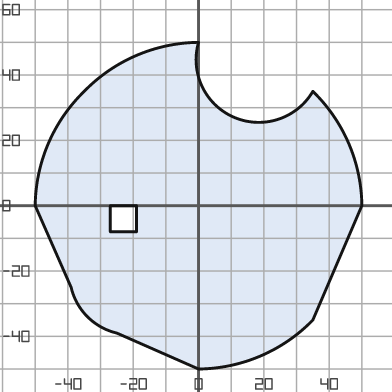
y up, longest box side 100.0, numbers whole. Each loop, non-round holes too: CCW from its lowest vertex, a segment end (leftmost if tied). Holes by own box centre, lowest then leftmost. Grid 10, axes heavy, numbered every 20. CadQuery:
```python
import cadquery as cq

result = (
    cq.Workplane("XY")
    .moveTo(0.0, -50.0)
    .threePointArc((19.0, -46.0), (35.0, -35.0))
    .lineTo(50.0, 0.0)
    .threePointArc((46.0, 19.0), (35.0, 35.0))
    .threePointArc((11.0, 27.0), (0.0, 50.0))
    .threePointArc((-19.0, 46.0), (-35.0, 35.0))
    .threePointArc((-46.0, 19.0), (-50.0, 0.0))
    .lineTo(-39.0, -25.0)
    .threePointArc((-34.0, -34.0), (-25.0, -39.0))
    .close()
    .moveTo(-27.0, -8.0)
    .lineTo(-19.0, -8.0)
    .lineTo(-19.0, 0.0)
    .lineTo(-27.0, 0.0)
    .close()
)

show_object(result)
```